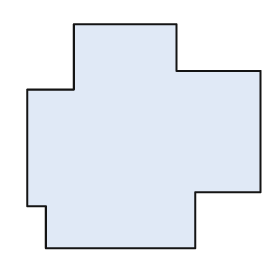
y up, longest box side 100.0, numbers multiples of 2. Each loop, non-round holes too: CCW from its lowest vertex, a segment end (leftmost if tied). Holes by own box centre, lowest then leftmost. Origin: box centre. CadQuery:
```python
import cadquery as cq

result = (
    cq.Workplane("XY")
    .moveTo(-42.0, -48.0)
    .lineTo(22.0, -48.0)
    .lineTo(22.0, -24.0)
    .lineTo(50.0, -24.0)
    .lineTo(50.0, 28.0)
    .lineTo(14.0, 28.0)
    .lineTo(14.0, 48.0)
    .lineTo(-30.0, 48.0)
    .lineTo(-30.0, 20.0)
    .lineTo(-50.0, 20.0)
    .lineTo(-50.0, -30.0)
    .lineTo(-42.0, -30.0)
    .close()
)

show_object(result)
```